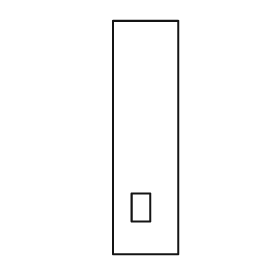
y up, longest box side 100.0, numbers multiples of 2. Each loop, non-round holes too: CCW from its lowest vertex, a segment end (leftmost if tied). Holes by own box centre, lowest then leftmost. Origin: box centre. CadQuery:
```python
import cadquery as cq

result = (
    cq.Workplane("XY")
    .moveTo(-14.0, -50.0)
    .lineTo(14.0, -50.0)
    .lineTo(14.0, 50.0)
    .lineTo(-14.0, 50.0)
    .close()
    .moveTo(-6.0, -36.0)
    .lineTo(2.0, -36.0)
    .lineTo(2.0, -24.0)
    .lineTo(-6.0, -24.0)
    .close()
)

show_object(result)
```